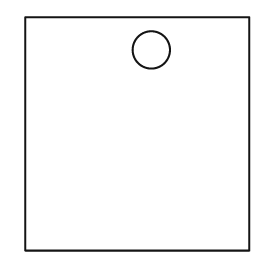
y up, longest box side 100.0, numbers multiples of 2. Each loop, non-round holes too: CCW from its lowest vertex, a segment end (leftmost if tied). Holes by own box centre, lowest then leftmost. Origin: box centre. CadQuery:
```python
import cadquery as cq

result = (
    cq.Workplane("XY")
    .moveTo(-48.0, -50.0)
    .lineTo(48.0, -50.0)
    .lineTo(48.0, 50.0)
    .lineTo(-48.0, 50.0)
    .close()
    .moveTo(6.0, 36.0)
    .circle(8.0)
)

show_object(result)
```